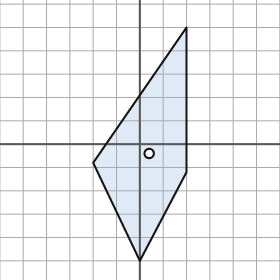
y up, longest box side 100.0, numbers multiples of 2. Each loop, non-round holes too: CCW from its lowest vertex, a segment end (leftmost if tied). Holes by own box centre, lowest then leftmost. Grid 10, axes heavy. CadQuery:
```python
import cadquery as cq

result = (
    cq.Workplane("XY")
    .moveTo(0.0, -50.0)
    .lineTo(20.0, -12.0)
    .lineTo(20.0, 50.0)
    .lineTo(-20.0, -8.0)
    .close()
    .moveTo(4.0, -4.0)
    .circle(2.0)
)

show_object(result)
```